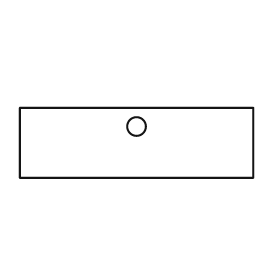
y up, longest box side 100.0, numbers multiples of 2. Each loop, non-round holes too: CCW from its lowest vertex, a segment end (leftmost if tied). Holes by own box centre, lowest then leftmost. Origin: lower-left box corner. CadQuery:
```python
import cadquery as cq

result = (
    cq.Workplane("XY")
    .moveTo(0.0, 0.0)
    .lineTo(100.0, 0.0)
    .lineTo(100.0, 30.0)
    .lineTo(0.0, 30.0)
    .close()
    .moveTo(50.0, 22.0)
    .circle(4.0)
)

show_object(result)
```